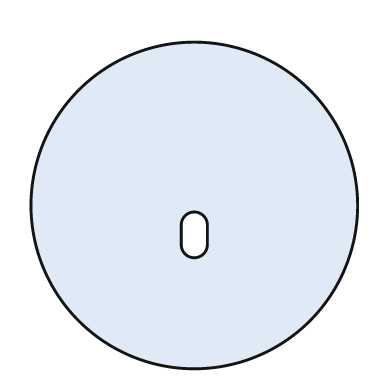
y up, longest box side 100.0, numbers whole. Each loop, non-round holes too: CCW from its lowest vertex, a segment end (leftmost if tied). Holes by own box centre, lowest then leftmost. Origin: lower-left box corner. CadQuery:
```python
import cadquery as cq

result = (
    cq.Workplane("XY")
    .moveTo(50.0, 50.0)
    .circle(50.0)
    .moveTo(46.0, 38.0)
    .threePointArc((50.0, 34.0), (54.0, 38.0))
    .lineTo(54.0, 44.0)
    .threePointArc((50.0, 48.0), (46.0, 44.0))
    .close()
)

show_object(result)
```